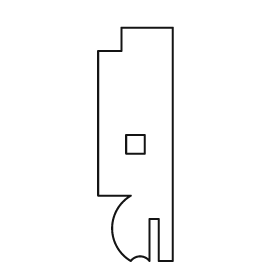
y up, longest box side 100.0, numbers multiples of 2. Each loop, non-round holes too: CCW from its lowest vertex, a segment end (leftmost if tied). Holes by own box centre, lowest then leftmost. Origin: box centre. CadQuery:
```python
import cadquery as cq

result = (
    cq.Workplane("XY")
    .moveTo(-2.0, -50.0)
    .threePointArc((2.0, -48.0), (6.0, -50.0))
    .lineTo(6.0, -32.0)
    .lineTo(10.0, -32.0)
    .lineTo(10.0, -50.0)
    .lineTo(16.0, -50.0)
    .lineTo(16.0, 50.0)
    .lineTo(-6.0, 50.0)
    .lineTo(-6.0, 40.0)
    .lineTo(-16.0, 40.0)
    .lineTo(-16.0, -22.0)
    .lineTo(-2.0, -22.0)
    .threePointArc((-10.0, -36.0), (-2.0, -50.0))
    .close()
    .moveTo(-4.0, -4.0)
    .lineTo(4.0, -4.0)
    .lineTo(4.0, 4.0)
    .lineTo(-4.0, 4.0)
    .close()
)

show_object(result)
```